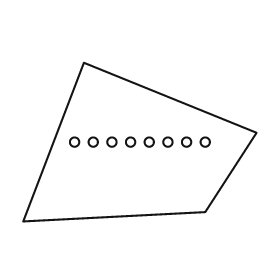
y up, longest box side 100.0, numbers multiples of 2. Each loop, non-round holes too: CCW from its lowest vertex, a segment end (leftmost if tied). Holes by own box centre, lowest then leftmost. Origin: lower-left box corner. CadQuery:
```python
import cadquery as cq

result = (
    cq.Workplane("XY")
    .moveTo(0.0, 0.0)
    .lineTo(78.0, 4.0)
    .lineTo(100.0, 38.0)
    .lineTo(26.0, 68.0)
    .close()
    .moveTo(22.0, 34.0)
    .circle(2.0)
    .moveTo(30.0, 34.0)
    .circle(2.0)
    .moveTo(38.0, 34.0)
    .circle(2.0)
    .moveTo(46.0, 34.0)
    .circle(2.0)
    .moveTo(54.0, 34.0)
    .circle(2.0)
    .moveTo(62.0, 34.0)
    .circle(2.0)
    .moveTo(70.0, 34.0)
    .circle(2.0)
    .moveTo(78.0, 34.0)
    .circle(2.0)
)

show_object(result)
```